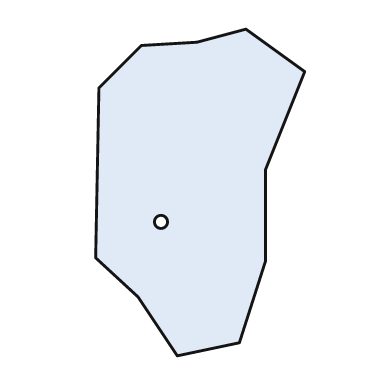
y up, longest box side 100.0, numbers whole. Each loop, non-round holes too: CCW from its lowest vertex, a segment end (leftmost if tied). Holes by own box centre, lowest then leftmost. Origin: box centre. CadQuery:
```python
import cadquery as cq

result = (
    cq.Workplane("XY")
    .moveTo(-7.0, -50.0)
    .lineTo(12.0, -46.0)
    .lineTo(20.0, -21.0)
    .lineTo(20.0, 7.0)
    .lineTo(32.0, 37.0)
    .lineTo(14.0, 50.0)
    .lineTo(-1.0, 46.0)
    .lineTo(-18.0, 45.0)
    .lineTo(-31.0, 32.0)
    .lineTo(-32.0, -20.0)
    .lineTo(-19.0, -32.0)
    .close()
    .moveTo(-12.0, -9.0)
    .circle(2.0)
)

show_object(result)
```